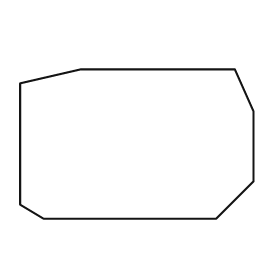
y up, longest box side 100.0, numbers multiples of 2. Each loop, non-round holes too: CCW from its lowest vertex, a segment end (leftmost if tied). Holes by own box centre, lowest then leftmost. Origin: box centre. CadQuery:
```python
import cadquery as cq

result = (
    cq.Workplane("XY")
    .moveTo(-40.0, -32.0)
    .lineTo(34.0, -32.0)
    .lineTo(50.0, -16.0)
    .lineTo(50.0, 14.0)
    .lineTo(42.0, 32.0)
    .lineTo(-24.0, 32.0)
    .lineTo(-50.0, 26.0)
    .lineTo(-50.0, -26.0)
    .close()
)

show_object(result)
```